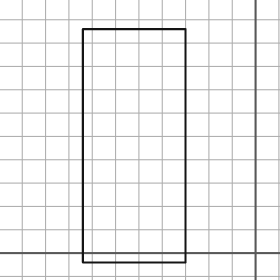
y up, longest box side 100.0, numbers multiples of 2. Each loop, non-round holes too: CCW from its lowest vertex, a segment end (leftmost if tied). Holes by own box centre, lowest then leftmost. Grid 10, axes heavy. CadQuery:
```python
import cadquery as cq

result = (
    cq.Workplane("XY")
    .moveTo(-74.0, -4.0)
    .lineTo(-30.0, -4.0)
    .lineTo(-30.0, 96.0)
    .lineTo(-74.0, 96.0)
    .close()
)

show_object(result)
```